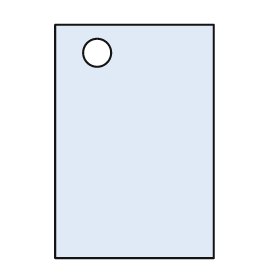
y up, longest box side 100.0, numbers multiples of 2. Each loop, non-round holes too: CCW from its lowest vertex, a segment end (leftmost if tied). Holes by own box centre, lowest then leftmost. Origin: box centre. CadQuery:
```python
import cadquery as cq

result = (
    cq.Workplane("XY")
    .moveTo(-34.0, -50.0)
    .lineTo(34.0, -50.0)
    .lineTo(34.0, 50.0)
    .lineTo(-34.0, 50.0)
    .close()
    .moveTo(-16.0, 38.0)
    .circle(6.0)
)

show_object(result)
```